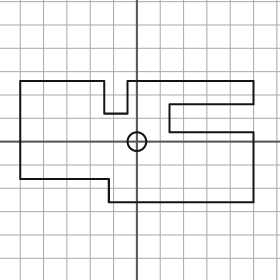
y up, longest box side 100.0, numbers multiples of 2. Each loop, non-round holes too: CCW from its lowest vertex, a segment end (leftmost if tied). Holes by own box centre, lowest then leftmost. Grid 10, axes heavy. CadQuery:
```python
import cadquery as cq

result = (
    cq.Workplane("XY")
    .moveTo(-12.0, -26.0)
    .lineTo(50.0, -26.0)
    .lineTo(50.0, 4.0)
    .lineTo(14.0, 4.0)
    .lineTo(14.0, 16.0)
    .lineTo(50.0, 16.0)
    .lineTo(50.0, 26.0)
    .lineTo(-4.0, 26.0)
    .lineTo(-4.0, 12.0)
    .lineTo(-14.0, 12.0)
    .lineTo(-14.0, 26.0)
    .lineTo(-50.0, 26.0)
    .lineTo(-50.0, -16.0)
    .lineTo(-12.0, -16.0)
    .close()
    .moveTo(0.0, 0.0)
    .circle(4.0)
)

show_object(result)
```